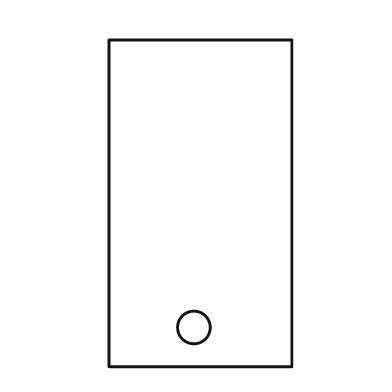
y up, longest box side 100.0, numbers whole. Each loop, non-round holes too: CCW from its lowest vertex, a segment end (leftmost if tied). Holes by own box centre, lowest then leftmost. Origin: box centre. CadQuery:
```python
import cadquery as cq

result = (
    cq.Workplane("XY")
    .moveTo(-28.0, -50.0)
    .lineTo(28.0, -50.0)
    .lineTo(28.0, 50.0)
    .lineTo(-28.0, 50.0)
    .close()
    .moveTo(-2.0, -38.0)
    .circle(5.0)
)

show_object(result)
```